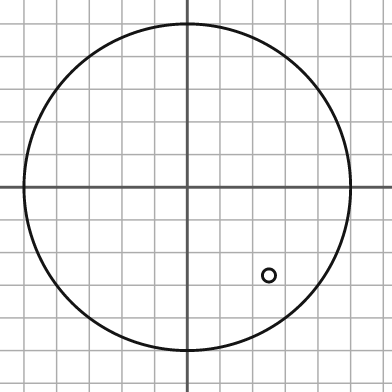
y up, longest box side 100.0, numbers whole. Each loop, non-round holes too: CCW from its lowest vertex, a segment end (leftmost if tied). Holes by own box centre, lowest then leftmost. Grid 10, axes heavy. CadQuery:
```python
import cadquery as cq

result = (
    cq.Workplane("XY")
    .moveTo(0.0, 0.0)
    .circle(50.0)
    .moveTo(25.0, -27.0)
    .circle(2.0)
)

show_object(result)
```